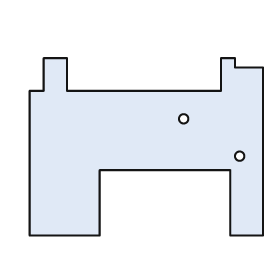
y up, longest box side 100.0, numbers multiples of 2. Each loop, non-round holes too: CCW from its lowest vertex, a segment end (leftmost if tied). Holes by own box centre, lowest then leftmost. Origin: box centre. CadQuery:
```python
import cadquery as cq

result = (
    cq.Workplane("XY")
    .moveTo(-50.0, -38.0)
    .lineTo(-20.0, -38.0)
    .lineTo(-20.0, -10.0)
    .lineTo(36.0, -10.0)
    .lineTo(36.0, -38.0)
    .lineTo(50.0, -38.0)
    .lineTo(50.0, 34.0)
    .lineTo(38.0, 34.0)
    .lineTo(38.0, 38.0)
    .lineTo(32.0, 38.0)
    .lineTo(32.0, 24.0)
    .lineTo(-34.0, 24.0)
    .lineTo(-34.0, 38.0)
    .lineTo(-44.0, 38.0)
    .lineTo(-44.0, 24.0)
    .lineTo(-50.0, 24.0)
    .close()
    .moveTo(40.0, -4.0)
    .circle(2.0)
    .moveTo(16.0, 12.0)
    .circle(2.0)
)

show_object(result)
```